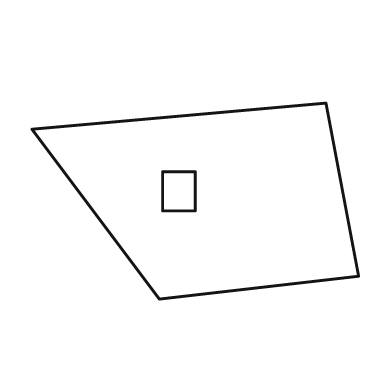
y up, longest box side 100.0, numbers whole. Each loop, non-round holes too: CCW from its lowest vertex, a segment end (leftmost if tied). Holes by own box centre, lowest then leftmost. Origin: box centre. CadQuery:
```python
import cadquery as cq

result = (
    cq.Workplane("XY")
    .moveTo(-11.0, -30.0)
    .lineTo(50.0, -23.0)
    .lineTo(40.0, 30.0)
    .lineTo(-50.0, 22.0)
    .close()
    .moveTo(-10.0, -3.0)
    .lineTo(0.0, -3.0)
    .lineTo(0.0, 9.0)
    .lineTo(-10.0, 9.0)
    .close()
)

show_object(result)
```